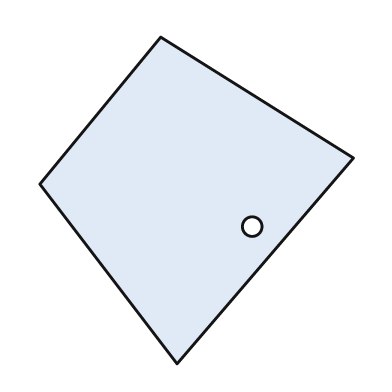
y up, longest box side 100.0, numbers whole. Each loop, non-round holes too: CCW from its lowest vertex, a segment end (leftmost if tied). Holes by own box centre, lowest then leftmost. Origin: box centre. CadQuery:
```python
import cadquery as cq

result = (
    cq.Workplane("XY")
    .moveTo(-6.0, -50.0)
    .lineTo(48.0, 13.0)
    .lineTo(-11.0, 50.0)
    .lineTo(-48.0, 5.0)
    .close()
    .moveTo(17.0, -8.0)
    .circle(3.0)
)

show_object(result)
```